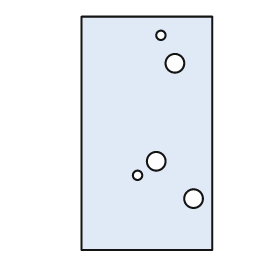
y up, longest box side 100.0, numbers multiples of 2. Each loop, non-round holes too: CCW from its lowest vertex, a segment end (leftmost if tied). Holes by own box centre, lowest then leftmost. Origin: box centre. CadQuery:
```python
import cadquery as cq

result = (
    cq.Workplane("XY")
    .moveTo(-28.0, -50.0)
    .lineTo(28.0, -50.0)
    .lineTo(28.0, 50.0)
    .lineTo(-28.0, 50.0)
    .close()
    .moveTo(20.0, -28.0)
    .circle(4.0)
    .moveTo(-4.0, -18.0)
    .circle(2.0)
    .moveTo(4.0, -12.0)
    .circle(4.0)
    .moveTo(12.0, 30.0)
    .circle(4.0)
    .moveTo(6.0, 42.0)
    .circle(2.0)
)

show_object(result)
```